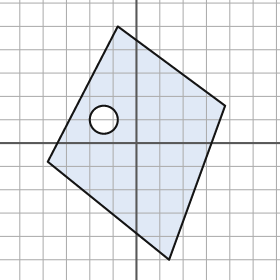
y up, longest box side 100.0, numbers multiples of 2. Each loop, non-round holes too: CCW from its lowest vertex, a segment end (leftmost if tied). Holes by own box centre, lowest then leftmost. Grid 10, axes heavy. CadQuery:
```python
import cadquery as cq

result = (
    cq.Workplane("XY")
    .moveTo(14.0, -50.0)
    .lineTo(38.0, 16.0)
    .lineTo(-8.0, 50.0)
    .lineTo(-38.0, -8.0)
    .close()
    .moveTo(-14.0, 10.0)
    .circle(6.0)
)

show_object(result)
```